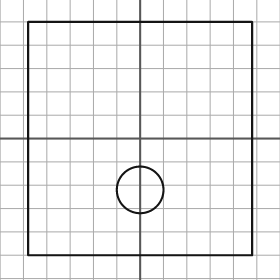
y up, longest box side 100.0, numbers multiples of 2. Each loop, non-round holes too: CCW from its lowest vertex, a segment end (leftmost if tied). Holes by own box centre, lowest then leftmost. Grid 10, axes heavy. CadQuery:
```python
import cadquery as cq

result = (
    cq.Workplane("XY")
    .moveTo(-48.0, -50.0)
    .lineTo(48.0, -50.0)
    .lineTo(48.0, 50.0)
    .lineTo(-48.0, 50.0)
    .close()
    .moveTo(0.0, -22.0)
    .circle(10.0)
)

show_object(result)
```